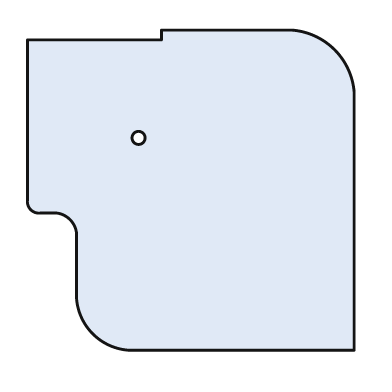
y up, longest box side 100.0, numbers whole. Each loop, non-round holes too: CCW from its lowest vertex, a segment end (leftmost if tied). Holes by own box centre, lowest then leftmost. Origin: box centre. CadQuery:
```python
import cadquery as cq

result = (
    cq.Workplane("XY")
    .moveTo(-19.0, -49.0)
    .lineTo(50.0, -49.0)
    .lineTo(50.0, 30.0)
    .threePointArc((44.0, 43.0), (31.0, 49.0))
    .lineTo(-9.0, 49.0)
    .lineTo(-9.0, 46.0)
    .lineTo(-50.0, 46.0)
    .lineTo(-50.0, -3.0)
    .threePointArc((-49.0, -6.0), (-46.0, -7.0))
    .lineTo(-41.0, -7.0)
    .threePointArc((-37.0, -9.0), (-35.0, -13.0))
    .lineTo(-35.0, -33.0)
    .threePointArc((-30.0, -44.0), (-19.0, -49.0))
    .close()
    .moveTo(-16.0, 16.0)
    .circle(2.0)
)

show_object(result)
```